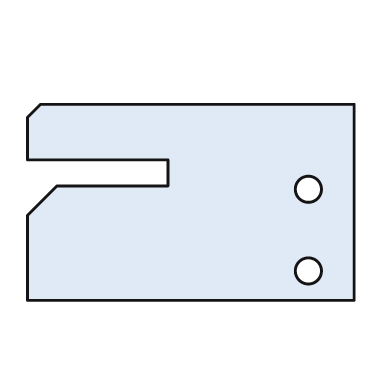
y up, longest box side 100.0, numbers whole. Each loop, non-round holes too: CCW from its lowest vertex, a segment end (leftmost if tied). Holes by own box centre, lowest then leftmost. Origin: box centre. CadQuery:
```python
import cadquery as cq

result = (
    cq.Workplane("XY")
    .moveTo(-50.0, -30.0)
    .lineTo(50.0, -30.0)
    .lineTo(50.0, 30.0)
    .lineTo(-46.0, 30.0)
    .lineTo(-50.0, 26.0)
    .lineTo(-50.0, 13.0)
    .lineTo(-7.0, 13.0)
    .lineTo(-7.0, 5.0)
    .lineTo(-41.0, 5.0)
    .lineTo(-50.0, -4.0)
    .close()
    .moveTo(36.0, -21.0)
    .circle(4.0)
    .moveTo(36.0, 4.0)
    .circle(4.0)
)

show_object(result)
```